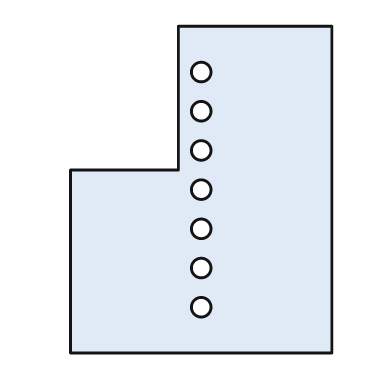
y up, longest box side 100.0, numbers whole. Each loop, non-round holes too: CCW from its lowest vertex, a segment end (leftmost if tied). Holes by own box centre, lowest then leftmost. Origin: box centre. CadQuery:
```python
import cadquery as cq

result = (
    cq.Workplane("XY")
    .moveTo(-40.0, -50.0)
    .lineTo(40.0, -50.0)
    .lineTo(40.0, 50.0)
    .lineTo(-7.0, 50.0)
    .lineTo(-7.0, 6.0)
    .lineTo(-40.0, 6.0)
    .close()
    .moveTo(0.0, -36.0)
    .circle(3.0)
    .moveTo(0.0, -24.0)
    .circle(3.0)
    .moveTo(0.0, -12.0)
    .circle(3.0)
    .moveTo(0.0, 0.0)
    .circle(3.0)
    .moveTo(0.0, 12.0)
    .circle(3.0)
    .moveTo(0.0, 24.0)
    .circle(3.0)
    .moveTo(0.0, 36.0)
    .circle(3.0)
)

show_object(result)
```